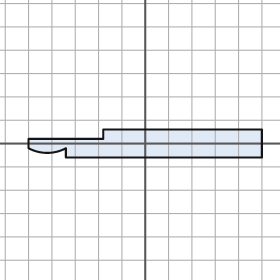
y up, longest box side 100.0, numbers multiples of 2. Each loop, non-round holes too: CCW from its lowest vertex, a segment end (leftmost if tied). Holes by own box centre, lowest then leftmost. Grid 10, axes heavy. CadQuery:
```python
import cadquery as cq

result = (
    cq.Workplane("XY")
    .moveTo(-34.0, -6.0)
    .lineTo(50.0, -6.0)
    .lineTo(50.0, 6.0)
    .lineTo(-18.0, 6.0)
    .lineTo(-18.0, 2.0)
    .lineTo(-50.0, 2.0)
    .lineTo(-50.0, -2.0)
    .threePointArc((-42.0, -4.0), (-34.0, -2.0))
    .close()
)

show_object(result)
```